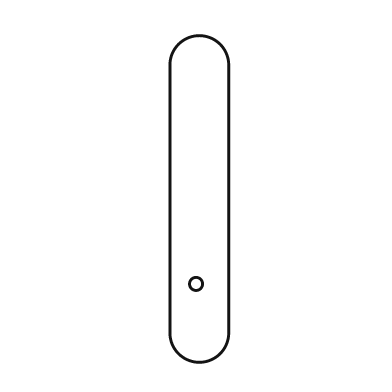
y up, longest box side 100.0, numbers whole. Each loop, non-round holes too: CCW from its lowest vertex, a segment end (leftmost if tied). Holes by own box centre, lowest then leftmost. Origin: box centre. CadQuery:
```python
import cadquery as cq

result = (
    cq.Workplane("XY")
    .moveTo(-9.0, -41.0)
    .threePointArc((0.0, -50.0), (9.0, -41.0))
    .lineTo(9.0, 41.0)
    .threePointArc((0.0, 50.0), (-9.0, 41.0))
    .close()
    .moveTo(-1.0, -26.0)
    .circle(2.0)
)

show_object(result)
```